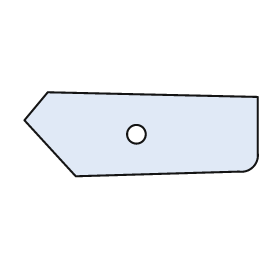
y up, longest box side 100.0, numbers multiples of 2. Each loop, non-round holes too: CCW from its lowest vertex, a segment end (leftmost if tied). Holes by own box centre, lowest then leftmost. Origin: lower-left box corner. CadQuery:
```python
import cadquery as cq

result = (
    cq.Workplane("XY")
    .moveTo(22.0, 0.0)
    .lineTo(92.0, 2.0)
    .threePointArc((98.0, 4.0), (100.0, 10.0))
    .lineTo(100.0, 34.0)
    .lineTo(10.0, 36.0)
    .lineTo(0.0, 24.0)
    .close()
    .moveTo(48.0, 18.0)
    .circle(4.0)
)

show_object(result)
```